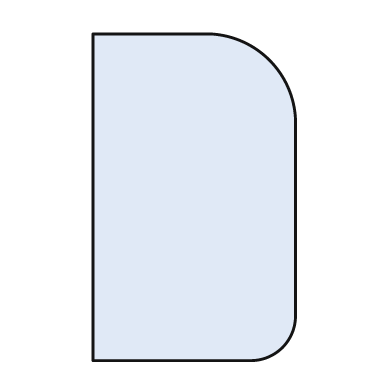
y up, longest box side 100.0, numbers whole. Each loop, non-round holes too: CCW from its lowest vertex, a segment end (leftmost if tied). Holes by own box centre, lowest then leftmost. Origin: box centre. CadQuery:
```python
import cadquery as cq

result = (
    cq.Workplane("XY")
    .moveTo(-31.0, -50.0)
    .lineTo(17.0, -50.0)
    .threePointArc((27.0, -46.0), (31.0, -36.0))
    .lineTo(31.0, 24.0)
    .threePointArc((23.0, 42.0), (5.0, 50.0))
    .lineTo(-31.0, 50.0)
    .close()
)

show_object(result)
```